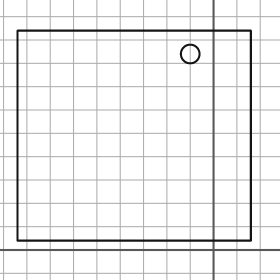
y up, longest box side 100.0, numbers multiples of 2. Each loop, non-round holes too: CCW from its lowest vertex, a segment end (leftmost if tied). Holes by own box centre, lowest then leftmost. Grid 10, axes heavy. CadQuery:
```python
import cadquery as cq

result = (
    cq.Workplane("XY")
    .moveTo(-84.0, 4.0)
    .lineTo(16.0, 4.0)
    .lineTo(16.0, 94.0)
    .lineTo(-84.0, 94.0)
    .close()
    .moveTo(-10.0, 84.0)
    .circle(4.0)
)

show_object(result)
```